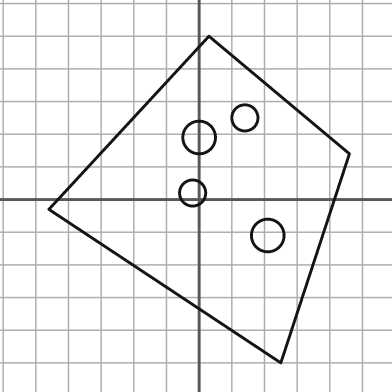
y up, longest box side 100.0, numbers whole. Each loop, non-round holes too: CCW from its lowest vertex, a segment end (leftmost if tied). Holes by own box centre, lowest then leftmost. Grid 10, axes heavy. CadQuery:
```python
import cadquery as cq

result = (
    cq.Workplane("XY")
    .moveTo(25.0, -50.0)
    .lineTo(46.0, 14.0)
    .lineTo(3.0, 50.0)
    .lineTo(-46.0, -3.0)
    .close()
    .moveTo(21.0, -11.0)
    .circle(5.0)
    .moveTo(-2.0, 2.0)
    .circle(4.0)
    .moveTo(0.0, 19.0)
    .circle(5.0)
    .moveTo(14.0, 25.0)
    .circle(4.0)
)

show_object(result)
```